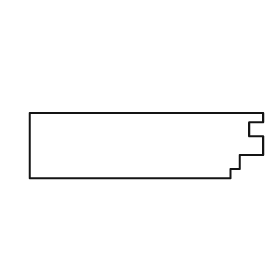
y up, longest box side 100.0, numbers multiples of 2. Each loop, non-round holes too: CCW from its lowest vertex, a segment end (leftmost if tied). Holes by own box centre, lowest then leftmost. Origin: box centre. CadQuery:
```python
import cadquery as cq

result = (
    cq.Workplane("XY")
    .moveTo(-50.0, -14.0)
    .lineTo(36.0, -14.0)
    .lineTo(36.0, -10.0)
    .lineTo(40.0, -10.0)
    .lineTo(40.0, -4.0)
    .lineTo(50.0, -4.0)
    .lineTo(50.0, 4.0)
    .lineTo(44.0, 4.0)
    .lineTo(44.0, 10.0)
    .lineTo(50.0, 10.0)
    .lineTo(50.0, 14.0)
    .lineTo(-50.0, 14.0)
    .close()
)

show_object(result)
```